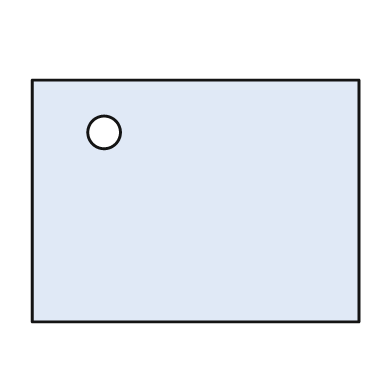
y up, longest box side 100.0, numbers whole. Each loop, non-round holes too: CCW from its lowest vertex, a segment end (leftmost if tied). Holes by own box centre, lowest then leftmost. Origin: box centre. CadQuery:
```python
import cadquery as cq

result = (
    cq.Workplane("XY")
    .moveTo(-50.0, -37.0)
    .lineTo(50.0, -37.0)
    .lineTo(50.0, 37.0)
    .lineTo(-50.0, 37.0)
    .close()
    .moveTo(-28.0, 21.0)
    .circle(5.0)
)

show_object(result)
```